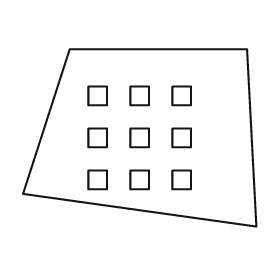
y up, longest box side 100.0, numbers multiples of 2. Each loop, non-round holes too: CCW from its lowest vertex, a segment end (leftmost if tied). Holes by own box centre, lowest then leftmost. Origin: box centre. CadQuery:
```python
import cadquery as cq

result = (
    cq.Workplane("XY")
    .moveTo(50.0, -38.0)
    .lineTo(46.0, 38.0)
    .lineTo(-30.0, 38.0)
    .lineTo(-50.0, -24.0)
    .close()
    .moveTo(-22.0, -22.0)
    .lineTo(-14.0, -22.0)
    .lineTo(-14.0, -14.0)
    .lineTo(-22.0, -14.0)
    .close()
    .moveTo(-4.0, -22.0)
    .lineTo(4.0, -22.0)
    .lineTo(4.0, -14.0)
    .lineTo(-4.0, -14.0)
    .close()
    .moveTo(14.0, -22.0)
    .lineTo(22.0, -22.0)
    .lineTo(22.0, -14.0)
    .lineTo(14.0, -14.0)
    .close()
    .moveTo(-22.0, -4.0)
    .lineTo(-14.0, -4.0)
    .lineTo(-14.0, 4.0)
    .lineTo(-22.0, 4.0)
    .close()
    .moveTo(-4.0, -4.0)
    .lineTo(4.0, -4.0)
    .lineTo(4.0, 4.0)
    .lineTo(-4.0, 4.0)
    .close()
    .moveTo(14.0, -4.0)
    .lineTo(22.0, -4.0)
    .lineTo(22.0, 4.0)
    .lineTo(14.0, 4.0)
    .close()
    .moveTo(-22.0, 14.0)
    .lineTo(-14.0, 14.0)
    .lineTo(-14.0, 22.0)
    .lineTo(-22.0, 22.0)
    .close()
    .moveTo(-4.0, 14.0)
    .lineTo(4.0, 14.0)
    .lineTo(4.0, 22.0)
    .lineTo(-4.0, 22.0)
    .close()
    .moveTo(14.0, 14.0)
    .lineTo(22.0, 14.0)
    .lineTo(22.0, 22.0)
    .lineTo(14.0, 22.0)
    .close()
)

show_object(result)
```